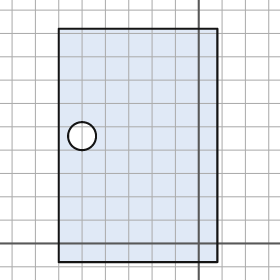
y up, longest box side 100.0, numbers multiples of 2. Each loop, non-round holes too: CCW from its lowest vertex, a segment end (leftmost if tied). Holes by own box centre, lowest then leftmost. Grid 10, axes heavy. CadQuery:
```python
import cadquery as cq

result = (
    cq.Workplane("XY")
    .moveTo(-60.0, -8.0)
    .lineTo(8.0, -8.0)
    .lineTo(8.0, 92.0)
    .lineTo(-60.0, 92.0)
    .close()
    .moveTo(-50.0, 46.0)
    .circle(6.0)
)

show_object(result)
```